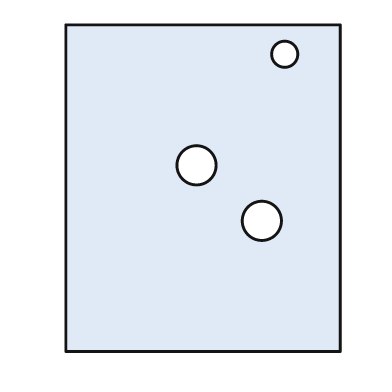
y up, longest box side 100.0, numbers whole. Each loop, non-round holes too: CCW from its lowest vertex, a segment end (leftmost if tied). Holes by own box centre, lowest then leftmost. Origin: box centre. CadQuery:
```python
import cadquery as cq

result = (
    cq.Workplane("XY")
    .moveTo(-42.0, -50.0)
    .lineTo(42.0, -50.0)
    .lineTo(42.0, 50.0)
    .lineTo(-42.0, 50.0)
    .close()
    .moveTo(18.0, -10.0)
    .circle(6.0)
    .moveTo(-2.0, 7.0)
    .circle(6.0)
    .moveTo(25.0, 41.0)
    .circle(4.0)
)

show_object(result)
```